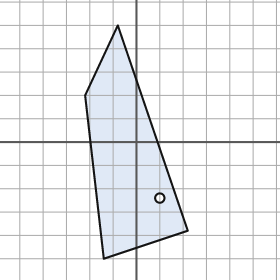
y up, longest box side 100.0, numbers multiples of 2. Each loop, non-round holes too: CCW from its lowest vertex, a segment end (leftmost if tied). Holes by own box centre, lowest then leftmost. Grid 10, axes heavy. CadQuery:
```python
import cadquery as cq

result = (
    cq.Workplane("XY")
    .moveTo(-14.0, -50.0)
    .lineTo(22.0, -38.0)
    .lineTo(-8.0, 50.0)
    .lineTo(-22.0, 20.0)
    .close()
    .moveTo(10.0, -24.0)
    .circle(2.0)
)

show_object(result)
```